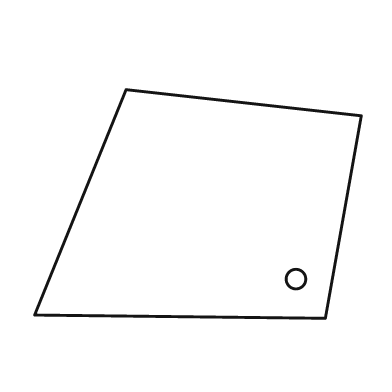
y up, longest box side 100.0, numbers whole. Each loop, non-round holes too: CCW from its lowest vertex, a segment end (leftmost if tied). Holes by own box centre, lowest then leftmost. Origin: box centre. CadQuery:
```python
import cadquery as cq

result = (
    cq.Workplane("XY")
    .moveTo(39.0, -35.0)
    .lineTo(50.0, 27.0)
    .lineTo(-22.0, 35.0)
    .lineTo(-50.0, -34.0)
    .close()
    .moveTo(30.0, -23.0)
    .circle(3.0)
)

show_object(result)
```